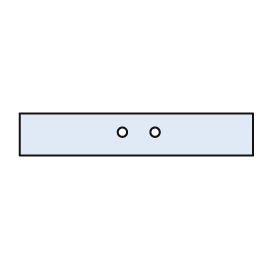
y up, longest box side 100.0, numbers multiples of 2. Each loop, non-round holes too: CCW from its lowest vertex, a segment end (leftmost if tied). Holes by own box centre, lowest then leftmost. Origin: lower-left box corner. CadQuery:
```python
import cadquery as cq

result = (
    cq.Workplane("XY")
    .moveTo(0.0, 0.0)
    .lineTo(100.0, 0.0)
    .lineTo(100.0, 18.0)
    .lineTo(0.0, 18.0)
    .close()
    .moveTo(44.0, 10.0)
    .circle(2.0)
    .moveTo(58.0, 10.0)
    .circle(2.0)
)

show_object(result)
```